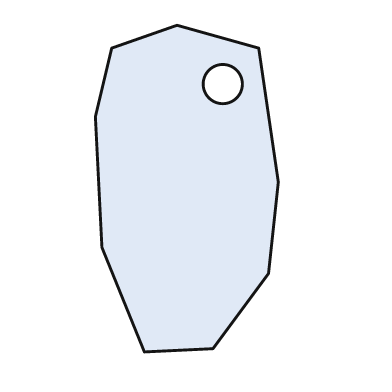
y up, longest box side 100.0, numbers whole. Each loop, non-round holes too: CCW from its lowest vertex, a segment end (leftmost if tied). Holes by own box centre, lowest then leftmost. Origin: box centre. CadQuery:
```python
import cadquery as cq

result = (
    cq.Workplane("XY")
    .moveTo(-13.0, -50.0)
    .lineTo(8.0, -49.0)
    .lineTo(25.0, -26.0)
    .lineTo(28.0, 2.0)
    .lineTo(22.0, 43.0)
    .lineTo(-3.0, 50.0)
    .lineTo(-23.0, 43.0)
    .lineTo(-28.0, 22.0)
    .lineTo(-26.0, -18.0)
    .close()
    .moveTo(11.0, 32.0)
    .circle(6.0)
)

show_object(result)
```